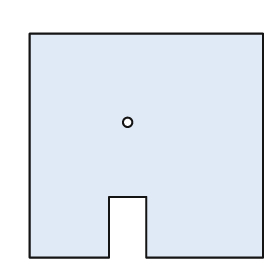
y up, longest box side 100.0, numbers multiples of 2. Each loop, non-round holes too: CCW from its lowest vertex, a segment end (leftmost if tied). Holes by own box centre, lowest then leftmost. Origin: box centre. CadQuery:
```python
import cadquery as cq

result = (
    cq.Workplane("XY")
    .moveTo(-50.0, -48.0)
    .lineTo(-16.0, -48.0)
    .lineTo(-16.0, -22.0)
    .lineTo(0.0, -22.0)
    .lineTo(0.0, -48.0)
    .lineTo(50.0, -48.0)
    .lineTo(50.0, 48.0)
    .lineTo(-50.0, 48.0)
    .close()
    .moveTo(-8.0, 10.0)
    .circle(2.0)
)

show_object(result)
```